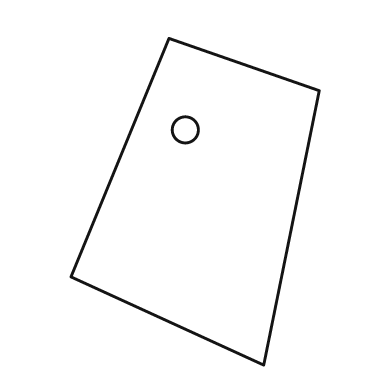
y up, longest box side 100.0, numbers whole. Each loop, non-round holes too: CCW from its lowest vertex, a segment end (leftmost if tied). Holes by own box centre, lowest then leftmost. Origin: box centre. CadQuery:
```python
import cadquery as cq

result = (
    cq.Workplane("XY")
    .moveTo(21.0, -50.0)
    .lineTo(38.0, 34.0)
    .lineTo(-8.0, 50.0)
    .lineTo(-38.0, -23.0)
    .close()
    .moveTo(-3.0, 22.0)
    .circle(4.0)
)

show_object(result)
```